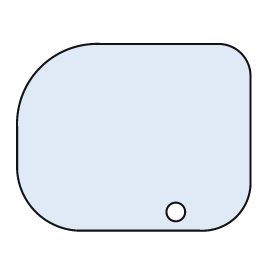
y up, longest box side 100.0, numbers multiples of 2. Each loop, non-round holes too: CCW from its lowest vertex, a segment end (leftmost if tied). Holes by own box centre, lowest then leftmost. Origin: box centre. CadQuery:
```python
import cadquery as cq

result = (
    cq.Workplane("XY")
    .moveTo(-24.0, -40.0)
    .lineTo(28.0, -40.0)
    .threePointArc((44.0, -34.0), (50.0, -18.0))
    .lineTo(50.0, 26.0)
    .threePointArc((46.0, 36.0), (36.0, 40.0))
    .lineTo(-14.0, 40.0)
    .threePointArc((-40.0, 30.0), (-50.0, 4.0))
    .lineTo(-50.0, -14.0)
    .threePointArc((-42.0, -32.0), (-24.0, -40.0))
    .close()
    .moveTo(18.0, -32.0)
    .circle(4.0)
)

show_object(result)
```